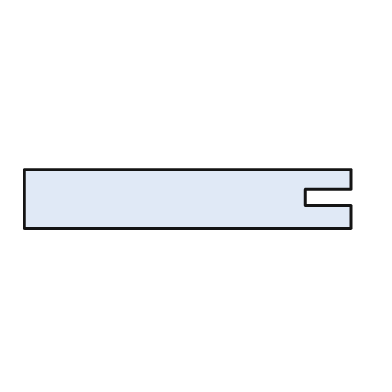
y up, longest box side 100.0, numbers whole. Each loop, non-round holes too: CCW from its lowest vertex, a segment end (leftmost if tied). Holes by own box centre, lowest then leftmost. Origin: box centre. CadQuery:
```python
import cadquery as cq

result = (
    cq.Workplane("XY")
    .moveTo(-50.0, -9.0)
    .lineTo(50.0, -9.0)
    .lineTo(50.0, -2.0)
    .lineTo(36.0, -2.0)
    .lineTo(36.0, 3.0)
    .lineTo(50.0, 3.0)
    .lineTo(50.0, 9.0)
    .lineTo(-50.0, 9.0)
    .close()
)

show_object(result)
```